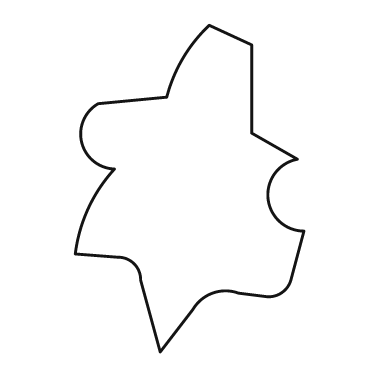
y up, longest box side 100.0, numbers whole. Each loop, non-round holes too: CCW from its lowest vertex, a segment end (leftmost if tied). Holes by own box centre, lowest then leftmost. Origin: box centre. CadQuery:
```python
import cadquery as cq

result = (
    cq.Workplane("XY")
    .moveTo(-9.0, -50.0)
    .lineTo(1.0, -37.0)
    .threePointArc((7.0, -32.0), (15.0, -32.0))
    .lineTo(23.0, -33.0)
    .threePointArc((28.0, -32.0), (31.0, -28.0))
    .lineTo(35.0, -13.0)
    .threePointArc((24.0, -3.0), (33.0, 9.0))
    .lineTo(19.0, 17.0)
    .lineTo(19.0, 44.0)
    .lineTo(6.0, 50.0)
    .threePointArc((-2.0, 40.0), (-7.0, 28.0))
    .lineTo(-28.0, 26.0)
    .threePointArc((-33.0, 14.0), (-23.0, 6.0))
    .threePointArc((-31.0, -6.0), (-35.0, -20.0))
    .lineTo(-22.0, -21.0)
    .threePointArc((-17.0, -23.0), (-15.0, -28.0))
    .close()
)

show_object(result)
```